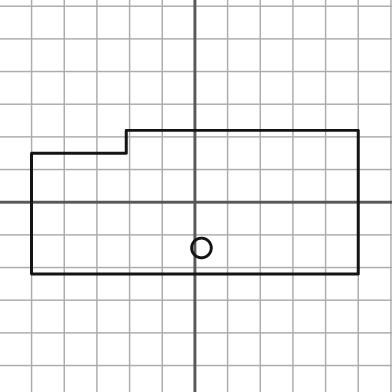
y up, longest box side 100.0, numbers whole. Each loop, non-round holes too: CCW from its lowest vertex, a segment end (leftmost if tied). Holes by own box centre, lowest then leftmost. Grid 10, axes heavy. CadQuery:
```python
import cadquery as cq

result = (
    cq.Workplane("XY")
    .moveTo(-50.0, -22.0)
    .lineTo(50.0, -22.0)
    .lineTo(50.0, 22.0)
    .lineTo(-21.0, 22.0)
    .lineTo(-21.0, 15.0)
    .lineTo(-50.0, 15.0)
    .close()
    .moveTo(2.0, -14.0)
    .circle(3.0)
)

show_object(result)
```